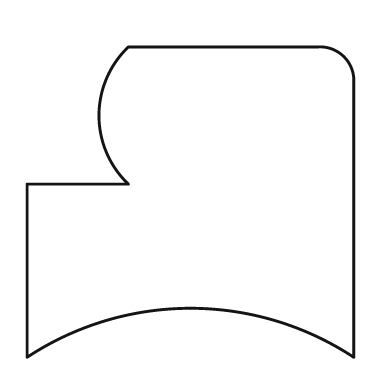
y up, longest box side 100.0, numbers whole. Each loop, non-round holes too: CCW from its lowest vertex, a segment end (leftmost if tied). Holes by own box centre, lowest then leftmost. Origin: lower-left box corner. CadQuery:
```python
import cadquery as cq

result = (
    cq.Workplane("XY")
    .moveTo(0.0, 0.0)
    .threePointArc((50.0, 15.0), (100.0, 0.0))
    .lineTo(100.0, 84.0)
    .threePointArc((97.0, 92.0), (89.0, 95.0))
    .lineTo(31.0, 95.0)
    .threePointArc((22.0, 74.0), (31.0, 53.0))
    .lineTo(0.0, 53.0)
    .close()
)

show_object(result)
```